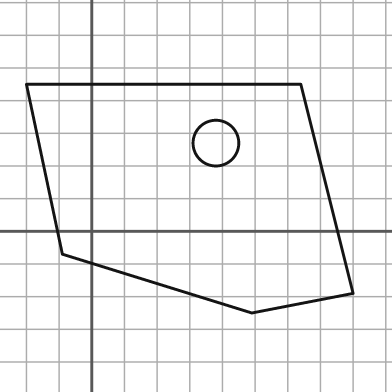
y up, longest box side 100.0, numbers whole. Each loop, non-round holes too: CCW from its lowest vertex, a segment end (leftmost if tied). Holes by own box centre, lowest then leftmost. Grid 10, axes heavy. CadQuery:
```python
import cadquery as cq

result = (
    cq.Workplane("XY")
    .moveTo(49.0, -25.0)
    .lineTo(80.0, -19.0)
    .lineTo(64.0, 45.0)
    .lineTo(-20.0, 45.0)
    .lineTo(-9.0, -7.0)
    .close()
    .moveTo(38.0, 27.0)
    .circle(7.0)
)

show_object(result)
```